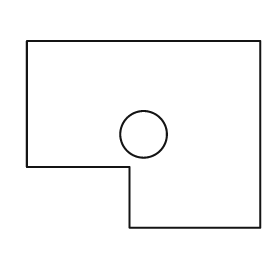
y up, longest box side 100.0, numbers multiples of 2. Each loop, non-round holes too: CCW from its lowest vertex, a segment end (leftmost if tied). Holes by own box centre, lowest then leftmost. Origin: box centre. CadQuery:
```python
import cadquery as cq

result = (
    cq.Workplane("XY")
    .moveTo(-6.0, -40.0)
    .lineTo(50.0, -40.0)
    .lineTo(50.0, 40.0)
    .lineTo(-50.0, 40.0)
    .lineTo(-50.0, -14.0)
    .lineTo(-6.0, -14.0)
    .close()
    .moveTo(0.0, 0.0)
    .circle(10.0)
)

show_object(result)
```